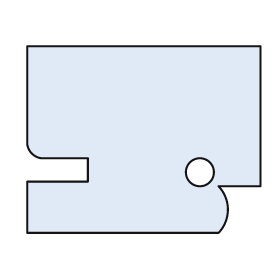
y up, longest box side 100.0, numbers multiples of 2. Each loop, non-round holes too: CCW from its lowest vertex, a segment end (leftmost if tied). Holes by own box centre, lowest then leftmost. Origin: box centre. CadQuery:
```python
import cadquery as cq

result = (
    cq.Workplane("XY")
    .moveTo(-50.0, -40.0)
    .lineTo(32.0, -40.0)
    .threePointArc((36.0, -30.0), (32.0, -20.0))
    .lineTo(50.0, -20.0)
    .lineTo(50.0, 40.0)
    .lineTo(-50.0, 40.0)
    .lineTo(-50.0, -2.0)
    .threePointArc((-48.0, -6.0), (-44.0, -8.0))
    .lineTo(-24.0, -8.0)
    .lineTo(-24.0, -18.0)
    .lineTo(-50.0, -18.0)
    .close()
    .moveTo(24.0, -14.0)
    .circle(6.0)
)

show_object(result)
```